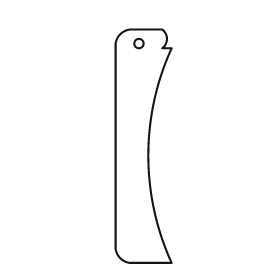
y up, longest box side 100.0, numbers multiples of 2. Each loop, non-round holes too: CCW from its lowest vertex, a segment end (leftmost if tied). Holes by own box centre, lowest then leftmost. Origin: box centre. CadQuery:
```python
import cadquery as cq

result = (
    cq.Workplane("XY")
    .moveTo(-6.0, -50.0)
    .lineTo(12.0, -50.0)
    .threePointArc((2.0, -4.0), (12.0, 42.0))
    .lineTo(8.0, 42.0)
    .threePointArc((10.0, 46.0), (8.0, 50.0))
    .lineTo(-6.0, 50.0)
    .threePointArc((-10.0, 48.0), (-12.0, 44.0))
    .lineTo(-12.0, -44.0)
    .threePointArc((-10.0, -48.0), (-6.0, -50.0))
    .close()
    .moveTo(-2.0, 44.0)
    .circle(2.0)
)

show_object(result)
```